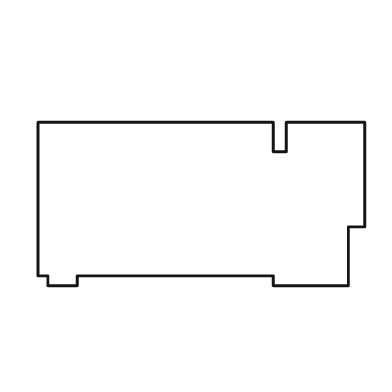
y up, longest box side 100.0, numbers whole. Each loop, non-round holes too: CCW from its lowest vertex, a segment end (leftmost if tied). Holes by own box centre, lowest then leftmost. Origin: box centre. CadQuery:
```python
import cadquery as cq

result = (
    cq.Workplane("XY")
    .moveTo(-47.0, -25.0)
    .lineTo(-38.0, -25.0)
    .lineTo(-38.0, -22.0)
    .lineTo(22.0, -22.0)
    .lineTo(22.0, -25.0)
    .lineTo(45.0, -25.0)
    .lineTo(45.0, -7.0)
    .lineTo(50.0, -7.0)
    .lineTo(50.0, 25.0)
    .lineTo(26.0, 25.0)
    .lineTo(26.0, 16.0)
    .lineTo(22.0, 16.0)
    .lineTo(22.0, 25.0)
    .lineTo(-50.0, 25.0)
    .lineTo(-50.0, -22.0)
    .lineTo(-47.0, -22.0)
    .close()
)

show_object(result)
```